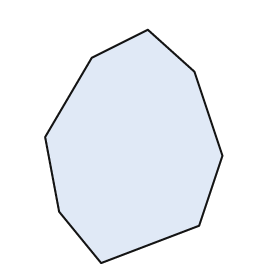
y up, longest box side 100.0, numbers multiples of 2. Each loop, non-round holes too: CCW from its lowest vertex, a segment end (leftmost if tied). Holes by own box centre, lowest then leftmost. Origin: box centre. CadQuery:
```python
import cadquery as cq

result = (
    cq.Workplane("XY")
    .moveTo(-14.0, -50.0)
    .lineTo(28.0, -34.0)
    .lineTo(38.0, -4.0)
    .lineTo(26.0, 32.0)
    .lineTo(6.0, 50.0)
    .lineTo(-18.0, 38.0)
    .lineTo(-38.0, 4.0)
    .lineTo(-32.0, -28.0)
    .close()
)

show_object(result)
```